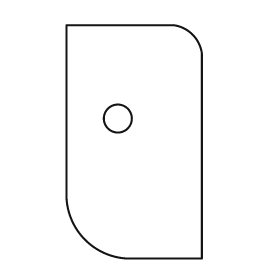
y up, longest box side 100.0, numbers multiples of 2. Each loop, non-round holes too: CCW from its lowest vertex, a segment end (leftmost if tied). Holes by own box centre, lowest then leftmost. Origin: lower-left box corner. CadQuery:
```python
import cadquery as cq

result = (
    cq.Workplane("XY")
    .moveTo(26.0, 0.0)
    .lineTo(58.0, 0.0)
    .lineTo(58.0, 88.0)
    .threePointArc((54.0, 96.0), (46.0, 100.0))
    .lineTo(0.0, 100.0)
    .lineTo(0.0, 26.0)
    .threePointArc((8.0, 8.0), (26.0, 0.0))
    .close()
    .moveTo(22.0, 60.0)
    .circle(6.0)
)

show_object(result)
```